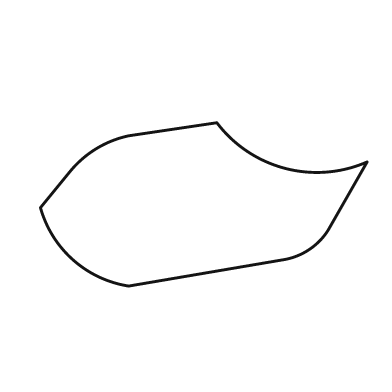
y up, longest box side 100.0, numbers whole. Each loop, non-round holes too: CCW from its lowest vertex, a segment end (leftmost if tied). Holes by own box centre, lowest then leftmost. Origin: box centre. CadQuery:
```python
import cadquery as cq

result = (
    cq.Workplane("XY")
    .moveTo(-23.0, -25.0)
    .lineTo(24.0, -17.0)
    .threePointArc((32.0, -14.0), (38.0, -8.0))
    .lineTo(50.0, 13.0)
    .threePointArc((25.0, 11.0), (4.0, 25.0))
    .lineTo(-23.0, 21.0)
    .threePointArc((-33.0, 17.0), (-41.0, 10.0))
    .lineTo(-50.0, -1.0)
    .threePointArc((-40.0, -17.0), (-23.0, -25.0))
    .close()
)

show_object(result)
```